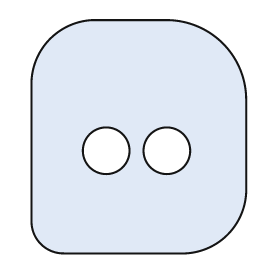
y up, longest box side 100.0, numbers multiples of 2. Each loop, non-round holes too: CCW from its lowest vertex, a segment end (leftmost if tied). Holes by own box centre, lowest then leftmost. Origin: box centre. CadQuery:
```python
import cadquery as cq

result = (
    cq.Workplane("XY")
    .moveTo(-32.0, -50.0)
    .lineTo(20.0, -50.0)
    .threePointArc((38.0, -42.0), (46.0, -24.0))
    .lineTo(46.0, 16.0)
    .threePointArc((36.0, 40.0), (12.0, 50.0))
    .lineTo(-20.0, 50.0)
    .threePointArc((-38.0, 42.0), (-46.0, 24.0))
    .lineTo(-46.0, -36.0)
    .threePointArc((-42.0, -46.0), (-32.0, -50.0))
    .close()
    .moveTo(-14.0, -6.0)
    .circle(10.0)
    .moveTo(12.0, -6.0)
    .circle(10.0)
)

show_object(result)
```